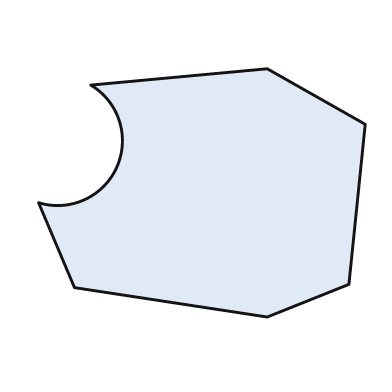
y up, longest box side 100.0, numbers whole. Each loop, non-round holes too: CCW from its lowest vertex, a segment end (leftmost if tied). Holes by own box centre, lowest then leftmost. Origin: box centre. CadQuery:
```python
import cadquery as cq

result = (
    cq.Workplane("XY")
    .moveTo(20.0, -38.0)
    .lineTo(45.0, -28.0)
    .lineTo(50.0, 21.0)
    .lineTo(20.0, 38.0)
    .lineTo(-34.0, 33.0)
    .threePointArc((-26.0, 8.0), (-50.0, -3.0))
    .lineTo(-39.0, -29.0)
    .close()
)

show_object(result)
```